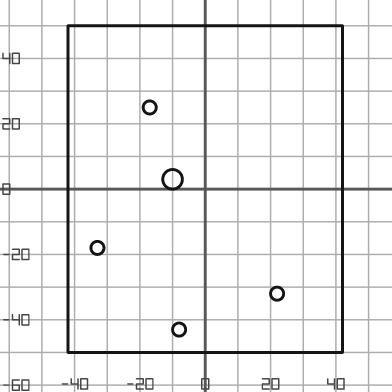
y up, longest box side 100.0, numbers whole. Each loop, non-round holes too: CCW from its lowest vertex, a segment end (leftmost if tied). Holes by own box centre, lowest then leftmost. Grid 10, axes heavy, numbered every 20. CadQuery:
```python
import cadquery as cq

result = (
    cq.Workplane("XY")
    .moveTo(-42.0, -50.0)
    .lineTo(42.0, -50.0)
    .lineTo(42.0, 50.0)
    .lineTo(-42.0, 50.0)
    .close()
    .moveTo(-8.0, -43.0)
    .circle(2.0)
    .moveTo(22.0, -32.0)
    .circle(2.0)
    .moveTo(-33.0, -18.0)
    .circle(2.0)
    .moveTo(-10.0, 3.0)
    .circle(3.0)
    .moveTo(-17.0, 25.0)
    .circle(2.0)
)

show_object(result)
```